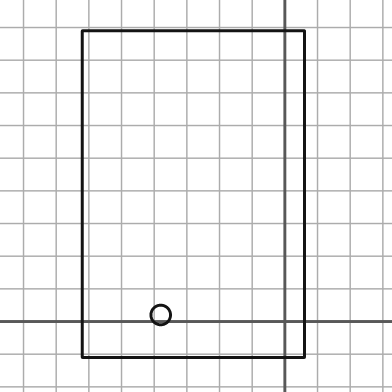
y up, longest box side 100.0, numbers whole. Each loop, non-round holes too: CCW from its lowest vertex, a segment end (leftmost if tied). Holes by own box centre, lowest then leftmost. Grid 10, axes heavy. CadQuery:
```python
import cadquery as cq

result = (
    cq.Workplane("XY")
    .moveTo(-62.0, -11.0)
    .lineTo(6.0, -11.0)
    .lineTo(6.0, 89.0)
    .lineTo(-62.0, 89.0)
    .close()
    .moveTo(-38.0, 2.0)
    .circle(3.0)
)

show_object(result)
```